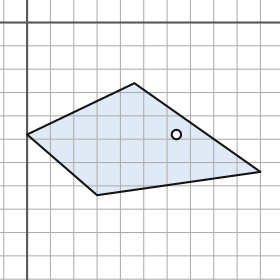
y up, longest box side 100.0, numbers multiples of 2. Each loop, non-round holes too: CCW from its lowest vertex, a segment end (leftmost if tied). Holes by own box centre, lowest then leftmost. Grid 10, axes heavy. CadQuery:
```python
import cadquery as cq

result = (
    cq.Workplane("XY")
    .moveTo(30.0, -74.0)
    .lineTo(100.0, -64.0)
    .lineTo(46.0, -26.0)
    .lineTo(0.0, -48.0)
    .close()
    .moveTo(64.0, -48.0)
    .circle(2.0)
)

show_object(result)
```